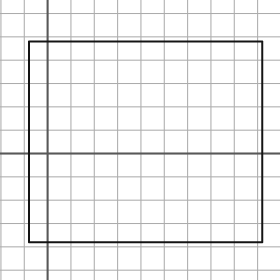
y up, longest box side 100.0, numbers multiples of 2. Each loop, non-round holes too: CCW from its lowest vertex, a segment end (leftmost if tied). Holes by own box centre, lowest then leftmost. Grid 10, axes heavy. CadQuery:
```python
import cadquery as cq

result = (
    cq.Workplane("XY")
    .moveTo(-8.0, -38.0)
    .lineTo(92.0, -38.0)
    .lineTo(92.0, 48.0)
    .lineTo(-8.0, 48.0)
    .close()
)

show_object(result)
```